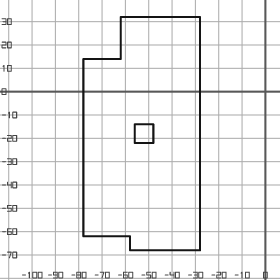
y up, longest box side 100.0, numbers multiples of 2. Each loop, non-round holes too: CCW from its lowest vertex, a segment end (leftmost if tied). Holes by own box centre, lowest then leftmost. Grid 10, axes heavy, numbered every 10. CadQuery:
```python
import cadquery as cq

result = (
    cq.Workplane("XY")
    .moveTo(-58.0, -68.0)
    .lineTo(-28.0, -68.0)
    .lineTo(-28.0, 32.0)
    .lineTo(-62.0, 32.0)
    .lineTo(-62.0, 14.0)
    .lineTo(-78.0, 14.0)
    .lineTo(-78.0, -62.0)
    .lineTo(-58.0, -62.0)
    .close()
    .moveTo(-56.0, -22.0)
    .lineTo(-48.0, -22.0)
    .lineTo(-48.0, -14.0)
    .lineTo(-56.0, -14.0)
    .close()
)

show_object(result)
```